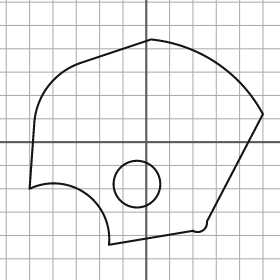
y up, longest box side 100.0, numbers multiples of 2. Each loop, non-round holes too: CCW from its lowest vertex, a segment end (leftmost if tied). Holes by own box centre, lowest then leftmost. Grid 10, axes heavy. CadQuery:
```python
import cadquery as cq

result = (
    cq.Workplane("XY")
    .moveTo(-16.0, -44.0)
    .lineTo(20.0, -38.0)
    .threePointArc((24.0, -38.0), (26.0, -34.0))
    .lineTo(50.0, 12.0)
    .threePointArc((30.0, 34.0), (2.0, 44.0))
    .lineTo(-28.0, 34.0)
    .threePointArc((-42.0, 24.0), (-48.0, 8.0))
    .lineTo(-50.0, -20.0)
    .threePointArc((-26.0, -22.0), (-16.0, -44.0))
    .close()
    .moveTo(-4.0, -18.0)
    .circle(10.0)
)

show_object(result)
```